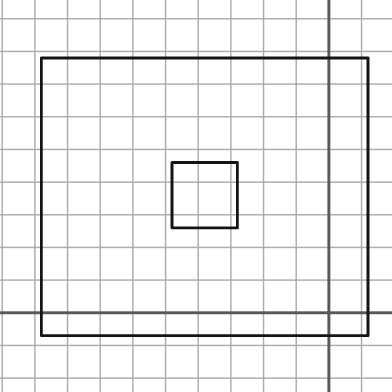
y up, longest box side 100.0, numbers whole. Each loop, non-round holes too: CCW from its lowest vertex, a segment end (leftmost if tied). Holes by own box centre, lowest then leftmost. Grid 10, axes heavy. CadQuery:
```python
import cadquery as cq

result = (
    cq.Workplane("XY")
    .moveTo(-88.0, -7.0)
    .lineTo(12.0, -7.0)
    .lineTo(12.0, 78.0)
    .lineTo(-88.0, 78.0)
    .close()
    .moveTo(-48.0, 26.0)
    .lineTo(-28.0, 26.0)
    .lineTo(-28.0, 46.0)
    .lineTo(-48.0, 46.0)
    .close()
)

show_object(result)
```